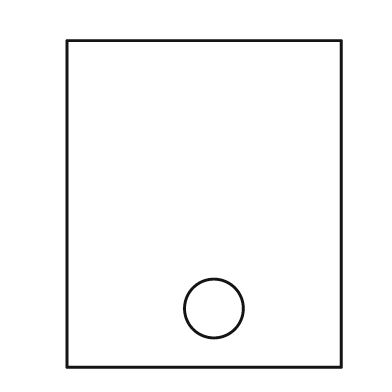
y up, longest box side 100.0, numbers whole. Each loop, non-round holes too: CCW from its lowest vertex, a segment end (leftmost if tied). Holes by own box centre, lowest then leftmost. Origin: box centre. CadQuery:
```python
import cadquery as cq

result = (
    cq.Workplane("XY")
    .moveTo(-42.0, -50.0)
    .lineTo(42.0, -50.0)
    .lineTo(42.0, 50.0)
    .lineTo(-42.0, 50.0)
    .close()
    .moveTo(3.0, -32.0)
    .circle(9.0)
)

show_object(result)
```